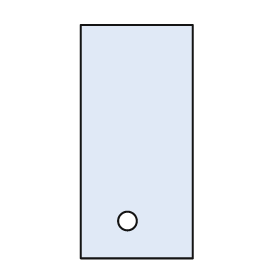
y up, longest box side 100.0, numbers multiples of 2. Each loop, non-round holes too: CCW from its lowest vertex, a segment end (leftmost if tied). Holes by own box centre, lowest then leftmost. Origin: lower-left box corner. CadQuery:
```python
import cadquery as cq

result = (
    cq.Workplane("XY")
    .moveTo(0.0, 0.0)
    .lineTo(48.0, 0.0)
    .lineTo(48.0, 100.0)
    .lineTo(0.0, 100.0)
    .close()
    .moveTo(20.0, 16.0)
    .circle(4.0)
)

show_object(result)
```